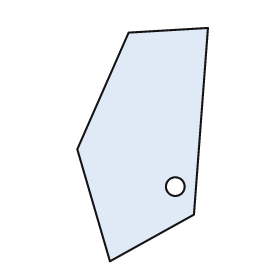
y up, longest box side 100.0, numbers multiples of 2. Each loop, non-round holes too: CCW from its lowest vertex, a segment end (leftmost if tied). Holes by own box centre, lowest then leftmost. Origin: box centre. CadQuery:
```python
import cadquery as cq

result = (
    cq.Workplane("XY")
    .moveTo(-14.0, -50.0)
    .lineTo(22.0, -30.0)
    .lineTo(28.0, 50.0)
    .lineTo(-6.0, 48.0)
    .lineTo(-28.0, -2.0)
    .close()
    .moveTo(14.0, -18.0)
    .circle(4.0)
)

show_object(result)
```